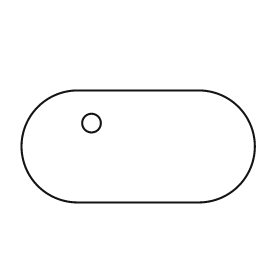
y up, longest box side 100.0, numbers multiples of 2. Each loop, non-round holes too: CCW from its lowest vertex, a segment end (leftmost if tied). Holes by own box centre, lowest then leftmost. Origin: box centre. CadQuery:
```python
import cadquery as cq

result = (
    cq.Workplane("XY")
    .moveTo(-26.0, -24.0)
    .lineTo(26.0, -24.0)
    .threePointArc((50.0, 0.0), (26.0, 24.0))
    .lineTo(-26.0, 24.0)
    .threePointArc((-50.0, 0.0), (-26.0, -24.0))
    .close()
    .moveTo(-20.0, 10.0)
    .circle(4.0)
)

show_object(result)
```